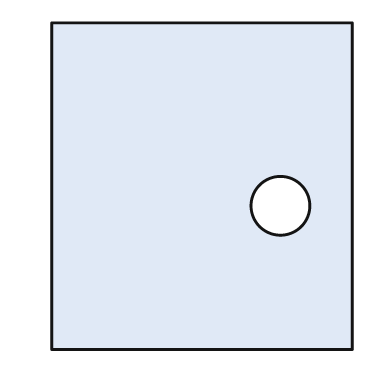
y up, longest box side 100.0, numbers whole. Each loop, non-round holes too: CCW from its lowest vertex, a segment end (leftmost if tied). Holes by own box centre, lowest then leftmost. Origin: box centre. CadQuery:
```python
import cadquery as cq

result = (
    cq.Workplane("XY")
    .moveTo(-46.0, -50.0)
    .lineTo(46.0, -50.0)
    .lineTo(46.0, 50.0)
    .lineTo(-46.0, 50.0)
    .close()
    .moveTo(24.0, -6.0)
    .circle(9.0)
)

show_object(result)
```